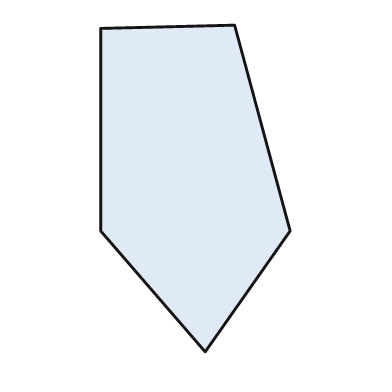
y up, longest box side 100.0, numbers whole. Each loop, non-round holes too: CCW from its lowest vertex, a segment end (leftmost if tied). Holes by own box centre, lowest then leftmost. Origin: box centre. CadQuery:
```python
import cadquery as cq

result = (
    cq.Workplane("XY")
    .moveTo(3.0, -50.0)
    .lineTo(29.0, -13.0)
    .lineTo(12.0, 50.0)
    .lineTo(-29.0, 49.0)
    .lineTo(-29.0, -13.0)
    .close()
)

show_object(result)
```